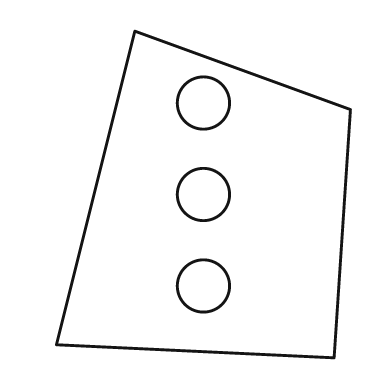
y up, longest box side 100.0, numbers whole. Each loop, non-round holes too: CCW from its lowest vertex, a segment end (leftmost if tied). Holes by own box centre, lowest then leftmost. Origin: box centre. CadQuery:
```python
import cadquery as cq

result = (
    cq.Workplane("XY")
    .moveTo(40.0, -50.0)
    .lineTo(45.0, 26.0)
    .lineTo(-21.0, 50.0)
    .lineTo(-45.0, -46.0)
    .close()
    .moveTo(0.0, -28.0)
    .circle(8.0)
    .moveTo(0.0, 0.0)
    .circle(8.0)
    .moveTo(0.0, 28.0)
    .circle(8.0)
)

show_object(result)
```